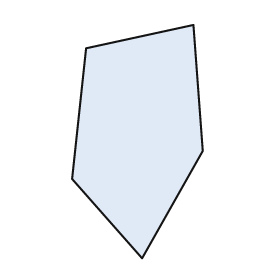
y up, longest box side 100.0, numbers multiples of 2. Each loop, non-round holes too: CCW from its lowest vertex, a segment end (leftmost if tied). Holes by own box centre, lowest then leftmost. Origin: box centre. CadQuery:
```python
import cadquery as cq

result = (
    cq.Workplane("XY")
    .moveTo(2.0, -50.0)
    .lineTo(28.0, -4.0)
    .lineTo(24.0, 50.0)
    .lineTo(-22.0, 40.0)
    .lineTo(-28.0, -16.0)
    .close()
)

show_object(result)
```